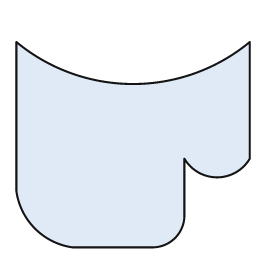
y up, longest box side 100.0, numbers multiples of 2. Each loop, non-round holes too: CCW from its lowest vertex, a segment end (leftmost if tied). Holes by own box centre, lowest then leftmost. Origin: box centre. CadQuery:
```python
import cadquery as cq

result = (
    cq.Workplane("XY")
    .moveTo(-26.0, -44.0)
    .lineTo(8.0, -44.0)
    .threePointArc((18.0, -40.0), (22.0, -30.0))
    .lineTo(22.0, -6.0)
    .threePointArc((36.0, -14.0), (50.0, -6.0))
    .lineTo(50.0, 44.0)
    .threePointArc((0.0, 26.0), (-50.0, 44.0))
    .lineTo(-50.0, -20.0)
    .threePointArc((-42.0, -36.0), (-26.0, -44.0))
    .close()
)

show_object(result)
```